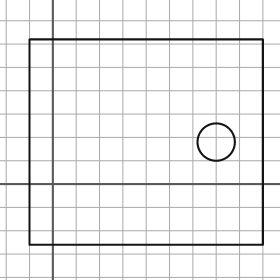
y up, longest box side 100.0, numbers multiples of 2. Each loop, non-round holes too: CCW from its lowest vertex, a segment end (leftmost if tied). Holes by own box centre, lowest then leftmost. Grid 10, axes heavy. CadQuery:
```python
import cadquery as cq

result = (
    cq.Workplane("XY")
    .moveTo(-10.0, -26.0)
    .lineTo(90.0, -26.0)
    .lineTo(90.0, 62.0)
    .lineTo(-10.0, 62.0)
    .close()
    .moveTo(70.0, 18.0)
    .circle(8.0)
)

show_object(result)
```